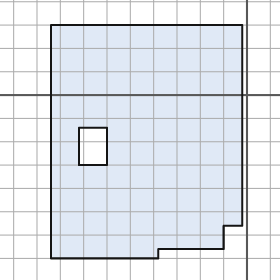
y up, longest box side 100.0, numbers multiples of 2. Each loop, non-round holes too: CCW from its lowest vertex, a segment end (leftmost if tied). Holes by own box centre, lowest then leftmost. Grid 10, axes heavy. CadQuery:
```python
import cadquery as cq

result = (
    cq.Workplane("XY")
    .moveTo(-84.0, -70.0)
    .lineTo(-38.0, -70.0)
    .lineTo(-38.0, -66.0)
    .lineTo(-10.0, -66.0)
    .lineTo(-10.0, -56.0)
    .lineTo(-2.0, -56.0)
    .lineTo(-2.0, 30.0)
    .lineTo(-84.0, 30.0)
    .close()
    .moveTo(-72.0, -30.0)
    .lineTo(-60.0, -30.0)
    .lineTo(-60.0, -14.0)
    .lineTo(-72.0, -14.0)
    .close()
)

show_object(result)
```